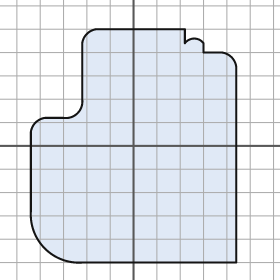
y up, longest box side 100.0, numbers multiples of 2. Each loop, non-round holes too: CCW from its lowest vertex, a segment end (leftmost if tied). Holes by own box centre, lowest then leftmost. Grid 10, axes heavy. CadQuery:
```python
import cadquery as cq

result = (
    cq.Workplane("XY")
    .moveTo(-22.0, -50.0)
    .lineTo(44.0, -50.0)
    .lineTo(44.0, 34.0)
    .threePointArc((42.0, 38.0), (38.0, 40.0))
    .lineTo(30.0, 40.0)
    .lineTo(30.0, 44.0)
    .threePointArc((26.0, 46.0), (22.0, 44.0))
    .lineTo(22.0, 50.0)
    .lineTo(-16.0, 50.0)
    .threePointArc((-20.0, 48.0), (-22.0, 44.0))
    .lineTo(-22.0, 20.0)
    .threePointArc((-24.0, 14.0), (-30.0, 12.0))
    .lineTo(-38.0, 12.0)
    .threePointArc((-42.0, 10.0), (-44.0, 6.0))
    .lineTo(-44.0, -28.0)
    .threePointArc((-38.0, -44.0), (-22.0, -50.0))
    .close()
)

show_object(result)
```